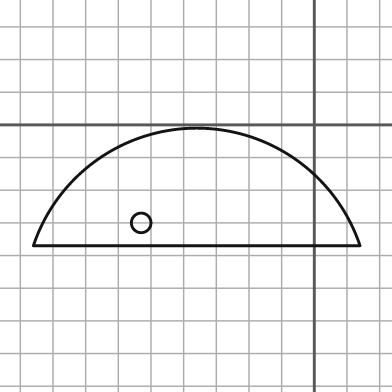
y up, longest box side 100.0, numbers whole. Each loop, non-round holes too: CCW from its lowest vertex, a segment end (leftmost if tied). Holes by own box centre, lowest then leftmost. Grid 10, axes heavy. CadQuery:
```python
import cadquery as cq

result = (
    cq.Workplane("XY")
    .moveTo(-86.0, -37.0)
    .lineTo(14.0, -37.0)
    .threePointArc((-36.0, -1.0), (-86.0, -37.0))
    .close()
    .moveTo(-53.0, -30.0)
    .circle(3.0)
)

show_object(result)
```